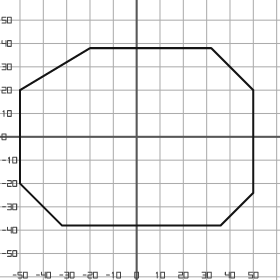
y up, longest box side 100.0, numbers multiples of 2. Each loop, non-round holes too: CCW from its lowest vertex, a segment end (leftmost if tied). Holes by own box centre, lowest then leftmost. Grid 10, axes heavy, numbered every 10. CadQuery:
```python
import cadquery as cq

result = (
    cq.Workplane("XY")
    .moveTo(-32.0, -38.0)
    .lineTo(36.0, -38.0)
    .lineTo(50.0, -24.0)
    .lineTo(50.0, 20.0)
    .lineTo(32.0, 38.0)
    .lineTo(-20.0, 38.0)
    .lineTo(-50.0, 20.0)
    .lineTo(-50.0, -20.0)
    .close()
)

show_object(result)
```